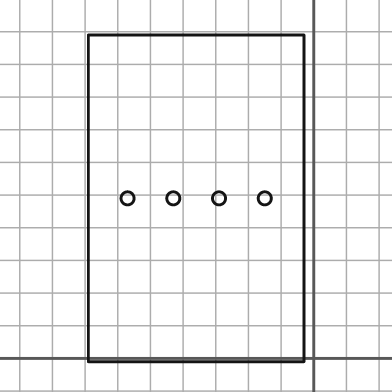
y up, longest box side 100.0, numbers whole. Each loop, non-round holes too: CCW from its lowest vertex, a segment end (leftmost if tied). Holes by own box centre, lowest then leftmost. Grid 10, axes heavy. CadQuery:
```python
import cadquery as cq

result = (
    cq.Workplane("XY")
    .moveTo(-69.0, -1.0)
    .lineTo(-3.0, -1.0)
    .lineTo(-3.0, 99.0)
    .lineTo(-69.0, 99.0)
    .close()
    .moveTo(-57.0, 49.0)
    .circle(2.0)
    .moveTo(-43.0, 49.0)
    .circle(2.0)
    .moveTo(-29.0, 49.0)
    .circle(2.0)
    .moveTo(-15.0, 49.0)
    .circle(2.0)
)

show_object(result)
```